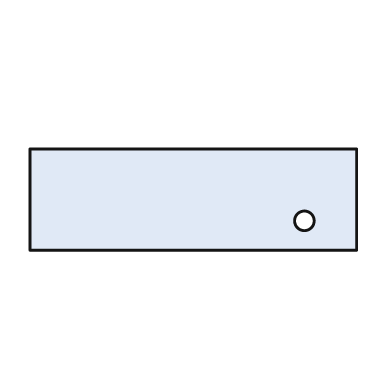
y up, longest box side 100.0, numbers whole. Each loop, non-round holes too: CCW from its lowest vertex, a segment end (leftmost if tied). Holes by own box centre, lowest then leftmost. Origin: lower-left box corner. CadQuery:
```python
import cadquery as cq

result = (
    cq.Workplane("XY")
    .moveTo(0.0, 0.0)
    .lineTo(100.0, 0.0)
    .lineTo(100.0, 31.0)
    .lineTo(0.0, 31.0)
    .close()
    .moveTo(84.0, 9.0)
    .circle(3.0)
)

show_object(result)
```